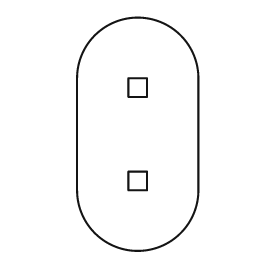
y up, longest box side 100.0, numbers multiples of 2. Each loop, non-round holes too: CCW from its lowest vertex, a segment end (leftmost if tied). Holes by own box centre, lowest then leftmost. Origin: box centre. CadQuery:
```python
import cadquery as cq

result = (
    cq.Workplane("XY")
    .moveTo(-26.0, -24.0)
    .threePointArc((0.0, -50.0), (26.0, -24.0))
    .lineTo(26.0, 24.0)
    .threePointArc((0.0, 50.0), (-26.0, 24.0))
    .close()
    .moveTo(-4.0, -24.0)
    .lineTo(4.0, -24.0)
    .lineTo(4.0, -16.0)
    .lineTo(-4.0, -16.0)
    .close()
    .moveTo(-4.0, 16.0)
    .lineTo(4.0, 16.0)
    .lineTo(4.0, 24.0)
    .lineTo(-4.0, 24.0)
    .close()
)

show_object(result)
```